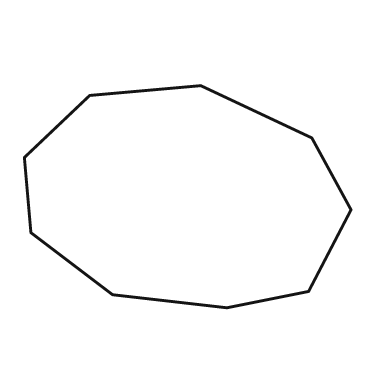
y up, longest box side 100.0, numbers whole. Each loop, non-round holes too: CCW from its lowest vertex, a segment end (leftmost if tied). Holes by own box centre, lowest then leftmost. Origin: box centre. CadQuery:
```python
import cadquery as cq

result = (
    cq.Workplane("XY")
    .moveTo(12.0, -34.0)
    .lineTo(37.0, -29.0)
    .lineTo(50.0, -4.0)
    .lineTo(38.0, 18.0)
    .lineTo(4.0, 34.0)
    .lineTo(-30.0, 31.0)
    .lineTo(-50.0, 12.0)
    .lineTo(-48.0, -11.0)
    .lineTo(-23.0, -30.0)
    .close()
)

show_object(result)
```